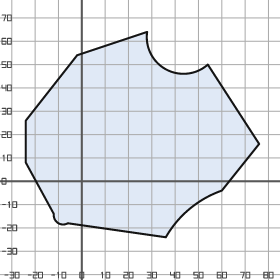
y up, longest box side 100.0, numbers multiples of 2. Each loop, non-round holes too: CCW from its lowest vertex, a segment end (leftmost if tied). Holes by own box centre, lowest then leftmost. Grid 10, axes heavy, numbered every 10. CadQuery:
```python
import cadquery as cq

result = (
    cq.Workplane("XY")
    .moveTo(36.0, -24.0)
    .threePointArc((46.0, -12.0), (60.0, -4.0))
    .lineTo(76.0, 16.0)
    .lineTo(54.0, 50.0)
    .threePointArc((36.0, 48.0), (28.0, 64.0))
    .lineTo(-2.0, 54.0)
    .lineTo(-24.0, 26.0)
    .lineTo(-24.0, 8.0)
    .lineTo(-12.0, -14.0)
    .threePointArc((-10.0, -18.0), (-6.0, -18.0))
    .close()
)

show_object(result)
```